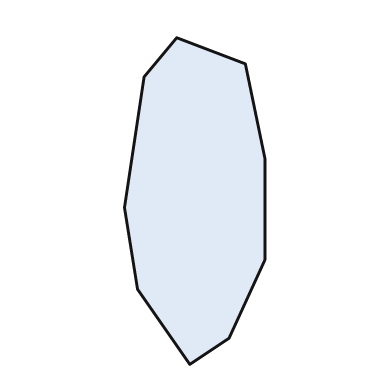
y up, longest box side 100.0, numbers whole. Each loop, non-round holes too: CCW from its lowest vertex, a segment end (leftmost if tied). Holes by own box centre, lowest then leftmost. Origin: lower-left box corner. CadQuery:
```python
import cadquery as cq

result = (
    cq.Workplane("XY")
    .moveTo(20.0, 0.0)
    .lineTo(32.0, 8.0)
    .lineTo(43.0, 32.0)
    .lineTo(43.0, 63.0)
    .lineTo(37.0, 92.0)
    .lineTo(16.0, 100.0)
    .lineTo(6.0, 88.0)
    .lineTo(0.0, 48.0)
    .lineTo(4.0, 23.0)
    .close()
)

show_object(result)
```